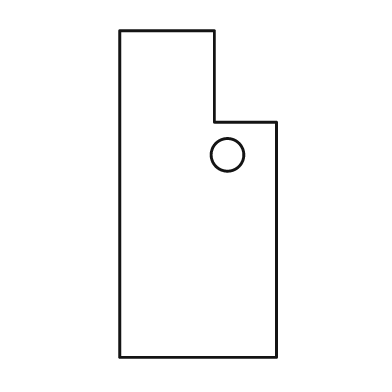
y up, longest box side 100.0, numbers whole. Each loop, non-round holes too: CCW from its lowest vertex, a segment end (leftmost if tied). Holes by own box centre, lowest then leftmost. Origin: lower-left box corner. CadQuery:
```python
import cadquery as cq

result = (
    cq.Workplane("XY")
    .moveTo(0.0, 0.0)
    .lineTo(48.0, 0.0)
    .lineTo(48.0, 72.0)
    .lineTo(29.0, 72.0)
    .lineTo(29.0, 100.0)
    .lineTo(0.0, 100.0)
    .close()
    .moveTo(33.0, 62.0)
    .circle(5.0)
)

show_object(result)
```